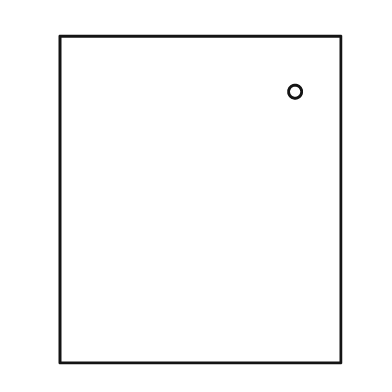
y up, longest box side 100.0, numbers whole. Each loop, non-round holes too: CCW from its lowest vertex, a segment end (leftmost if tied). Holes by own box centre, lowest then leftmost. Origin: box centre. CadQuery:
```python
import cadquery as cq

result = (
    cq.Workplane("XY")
    .moveTo(-43.0, -50.0)
    .lineTo(43.0, -50.0)
    .lineTo(43.0, 50.0)
    .lineTo(-43.0, 50.0)
    .close()
    .moveTo(29.0, 33.0)
    .circle(2.0)
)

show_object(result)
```